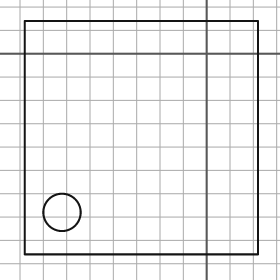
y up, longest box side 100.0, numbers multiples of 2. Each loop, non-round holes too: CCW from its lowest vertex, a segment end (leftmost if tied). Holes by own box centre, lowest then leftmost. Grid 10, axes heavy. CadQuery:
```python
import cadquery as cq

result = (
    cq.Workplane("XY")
    .moveTo(-78.0, -86.0)
    .lineTo(22.0, -86.0)
    .lineTo(22.0, 14.0)
    .lineTo(-78.0, 14.0)
    .close()
    .moveTo(-62.0, -68.0)
    .circle(8.0)
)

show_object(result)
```